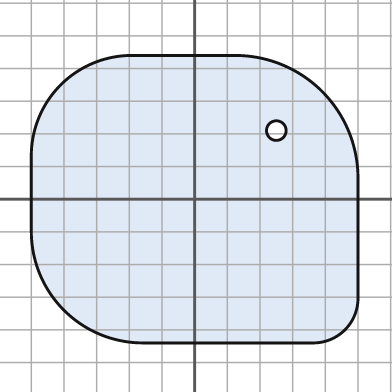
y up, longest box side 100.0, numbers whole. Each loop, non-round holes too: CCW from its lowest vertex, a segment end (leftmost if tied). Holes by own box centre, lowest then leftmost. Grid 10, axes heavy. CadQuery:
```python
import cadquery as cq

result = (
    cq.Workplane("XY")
    .moveTo(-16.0, -44.0)
    .lineTo(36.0, -44.0)
    .threePointArc((46.0, -40.0), (50.0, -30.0))
    .lineTo(50.0, 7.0)
    .threePointArc((39.0, 33.0), (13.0, 44.0))
    .lineTo(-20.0, 44.0)
    .threePointArc((-41.0, 35.0), (-50.0, 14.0))
    .lineTo(-50.0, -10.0)
    .threePointArc((-40.0, -34.0), (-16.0, -44.0))
    .close()
    .moveTo(25.0, 21.0)
    .circle(3.0)
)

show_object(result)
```